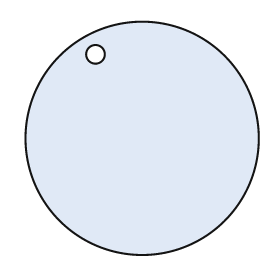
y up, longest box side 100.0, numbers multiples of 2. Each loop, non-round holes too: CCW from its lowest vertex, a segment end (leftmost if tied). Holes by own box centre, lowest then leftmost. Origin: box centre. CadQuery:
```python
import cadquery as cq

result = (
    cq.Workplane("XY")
    .moveTo(0.0, 0.0)
    .circle(50.0)
    .moveTo(-20.0, 36.0)
    .circle(4.0)
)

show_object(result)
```